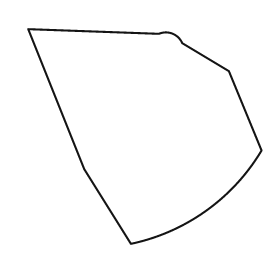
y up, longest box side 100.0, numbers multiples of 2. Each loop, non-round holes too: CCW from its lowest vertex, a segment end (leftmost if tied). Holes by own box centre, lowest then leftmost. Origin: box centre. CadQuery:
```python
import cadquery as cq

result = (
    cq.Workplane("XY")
    .moveTo(-6.0, -46.0)
    .threePointArc((26.0, -32.0), (50.0, -6.0))
    .lineTo(36.0, 28.0)
    .lineTo(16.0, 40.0)
    .threePointArc((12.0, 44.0), (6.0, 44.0))
    .lineTo(-50.0, 46.0)
    .lineTo(-26.0, -14.0)
    .close()
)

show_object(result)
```